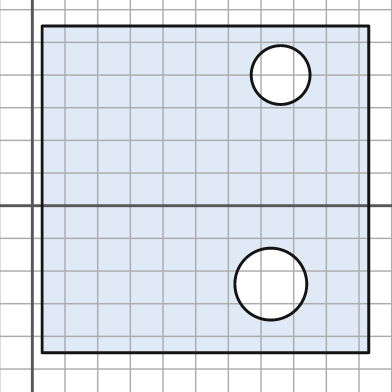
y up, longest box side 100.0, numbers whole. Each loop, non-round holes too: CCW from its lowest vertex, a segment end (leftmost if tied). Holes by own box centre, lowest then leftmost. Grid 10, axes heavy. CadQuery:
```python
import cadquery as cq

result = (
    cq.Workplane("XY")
    .moveTo(3.0, -45.0)
    .lineTo(103.0, -45.0)
    .lineTo(103.0, 55.0)
    .lineTo(3.0, 55.0)
    .close()
    .moveTo(73.0, -24.0)
    .circle(11.0)
    .moveTo(76.0, 40.0)
    .circle(9.0)
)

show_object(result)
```